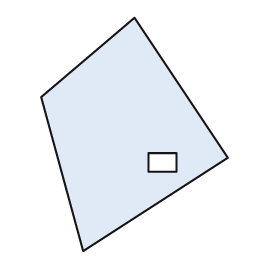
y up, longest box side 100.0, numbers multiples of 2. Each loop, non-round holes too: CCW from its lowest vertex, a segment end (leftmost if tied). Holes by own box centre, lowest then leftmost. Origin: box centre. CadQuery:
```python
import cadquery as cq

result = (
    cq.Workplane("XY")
    .moveTo(-22.0, -50.0)
    .lineTo(40.0, -10.0)
    .lineTo(0.0, 50.0)
    .lineTo(-40.0, 16.0)
    .close()
    .moveTo(6.0, -16.0)
    .lineTo(18.0, -16.0)
    .lineTo(18.0, -8.0)
    .lineTo(6.0, -8.0)
    .close()
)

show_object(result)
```